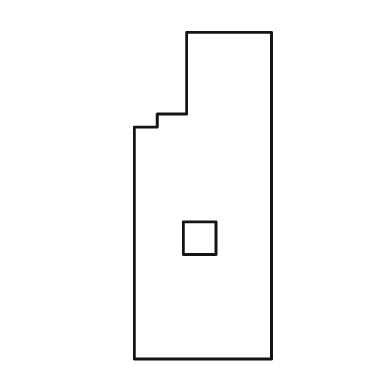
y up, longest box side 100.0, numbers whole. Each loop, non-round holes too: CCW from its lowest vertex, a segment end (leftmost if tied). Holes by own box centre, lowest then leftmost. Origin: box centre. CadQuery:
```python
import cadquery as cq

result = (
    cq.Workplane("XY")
    .moveTo(-21.0, -50.0)
    .lineTo(21.0, -50.0)
    .lineTo(21.0, 50.0)
    .lineTo(-5.0, 50.0)
    .lineTo(-5.0, 25.0)
    .lineTo(-14.0, 25.0)
    .lineTo(-14.0, 21.0)
    .lineTo(-21.0, 21.0)
    .close()
    .moveTo(-6.0, -18.0)
    .lineTo(4.0, -18.0)
    .lineTo(4.0, -8.0)
    .lineTo(-6.0, -8.0)
    .close()
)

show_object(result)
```